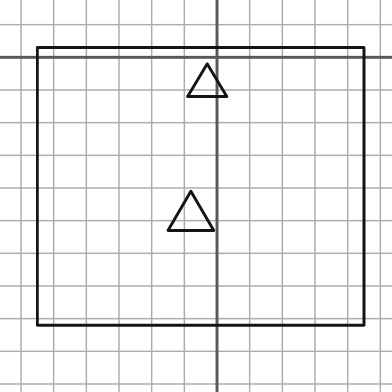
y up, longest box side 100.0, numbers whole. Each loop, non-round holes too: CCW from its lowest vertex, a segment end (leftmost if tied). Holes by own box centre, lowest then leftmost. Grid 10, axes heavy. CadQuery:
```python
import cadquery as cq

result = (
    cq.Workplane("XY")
    .moveTo(-55.0, -82.0)
    .lineTo(45.0, -82.0)
    .lineTo(45.0, 3.0)
    .lineTo(-55.0, 3.0)
    .close()
    .moveTo(-15.0, -53.0)
    .lineTo(-1.0, -53.0)
    .lineTo(-8.0, -41.0)
    .close()
    .moveTo(-9.0, -12.0)
    .lineTo(3.0, -12.0)
    .lineTo(-3.0, -2.0)
    .close()
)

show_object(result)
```